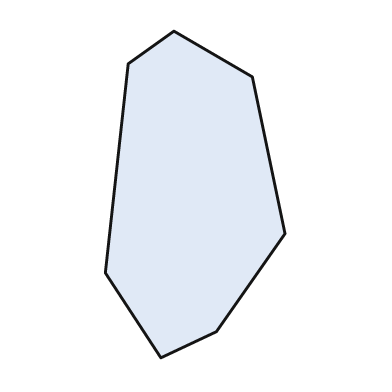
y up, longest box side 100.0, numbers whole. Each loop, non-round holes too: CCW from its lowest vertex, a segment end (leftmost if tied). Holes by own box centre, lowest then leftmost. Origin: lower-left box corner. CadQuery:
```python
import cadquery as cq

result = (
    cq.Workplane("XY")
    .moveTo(17.0, 0.0)
    .lineTo(34.0, 8.0)
    .lineTo(55.0, 38.0)
    .lineTo(45.0, 86.0)
    .lineTo(21.0, 100.0)
    .lineTo(7.0, 90.0)
    .lineTo(0.0, 26.0)
    .close()
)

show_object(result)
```